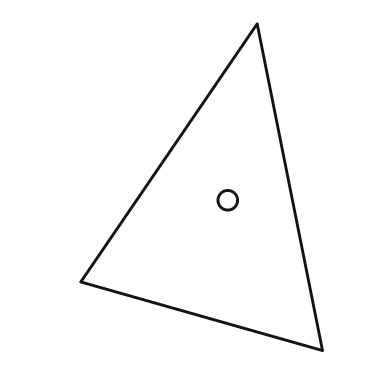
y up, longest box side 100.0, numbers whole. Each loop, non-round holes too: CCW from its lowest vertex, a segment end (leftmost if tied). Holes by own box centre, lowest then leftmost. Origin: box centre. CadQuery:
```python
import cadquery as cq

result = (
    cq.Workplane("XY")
    .moveTo(37.0, -50.0)
    .lineTo(17.0, 50.0)
    .lineTo(-37.0, -29.0)
    .close()
    .moveTo(8.0, -4.0)
    .circle(3.0)
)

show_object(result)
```